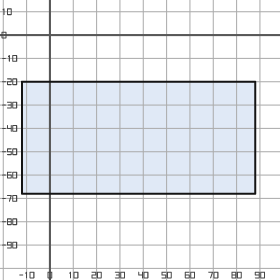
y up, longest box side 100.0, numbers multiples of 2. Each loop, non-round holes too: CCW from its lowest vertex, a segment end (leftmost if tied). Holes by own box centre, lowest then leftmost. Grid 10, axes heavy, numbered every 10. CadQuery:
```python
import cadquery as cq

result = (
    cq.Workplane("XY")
    .moveTo(-12.0, -68.0)
    .lineTo(88.0, -68.0)
    .lineTo(88.0, -20.0)
    .lineTo(-12.0, -20.0)
    .close()
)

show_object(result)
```